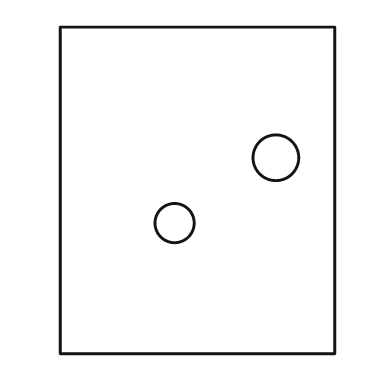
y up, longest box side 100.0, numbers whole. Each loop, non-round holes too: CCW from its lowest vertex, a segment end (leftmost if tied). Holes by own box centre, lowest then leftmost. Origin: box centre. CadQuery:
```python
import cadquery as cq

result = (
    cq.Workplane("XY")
    .moveTo(-42.0, -50.0)
    .lineTo(42.0, -50.0)
    .lineTo(42.0, 50.0)
    .lineTo(-42.0, 50.0)
    .close()
    .moveTo(-7.0, -10.0)
    .circle(6.0)
    .moveTo(24.0, 10.0)
    .circle(7.0)
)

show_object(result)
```